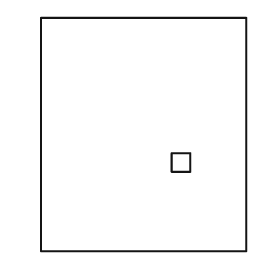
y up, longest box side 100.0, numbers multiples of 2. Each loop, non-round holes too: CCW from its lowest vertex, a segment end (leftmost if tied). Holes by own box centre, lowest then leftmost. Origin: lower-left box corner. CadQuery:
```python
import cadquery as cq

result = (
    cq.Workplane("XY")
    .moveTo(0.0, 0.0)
    .lineTo(88.0, 0.0)
    .lineTo(88.0, 100.0)
    .lineTo(0.0, 100.0)
    .close()
    .moveTo(56.0, 34.0)
    .lineTo(64.0, 34.0)
    .lineTo(64.0, 42.0)
    .lineTo(56.0, 42.0)
    .close()
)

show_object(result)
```